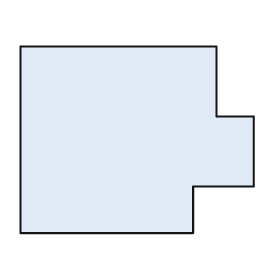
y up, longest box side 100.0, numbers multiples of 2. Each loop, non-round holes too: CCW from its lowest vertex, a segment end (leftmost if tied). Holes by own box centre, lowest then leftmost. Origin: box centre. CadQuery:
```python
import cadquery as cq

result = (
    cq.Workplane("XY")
    .moveTo(-50.0, -40.0)
    .lineTo(24.0, -40.0)
    .lineTo(24.0, -20.0)
    .lineTo(50.0, -20.0)
    .lineTo(50.0, 10.0)
    .lineTo(34.0, 10.0)
    .lineTo(34.0, 40.0)
    .lineTo(-50.0, 40.0)
    .close()
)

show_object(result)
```